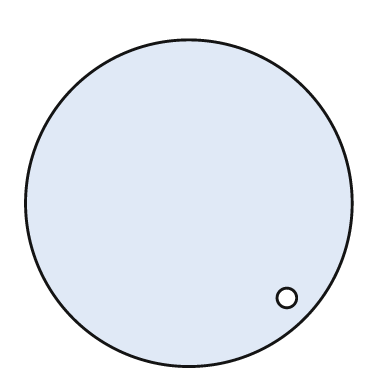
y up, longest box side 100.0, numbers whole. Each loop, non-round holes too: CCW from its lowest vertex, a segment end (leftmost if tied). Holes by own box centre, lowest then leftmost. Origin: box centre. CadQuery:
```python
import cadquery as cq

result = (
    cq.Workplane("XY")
    .moveTo(0.0, 0.0)
    .circle(50.0)
    .moveTo(30.0, -29.0)
    .circle(3.0)
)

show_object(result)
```